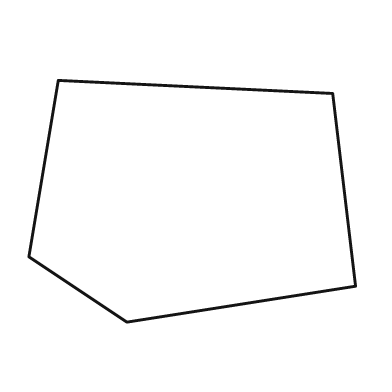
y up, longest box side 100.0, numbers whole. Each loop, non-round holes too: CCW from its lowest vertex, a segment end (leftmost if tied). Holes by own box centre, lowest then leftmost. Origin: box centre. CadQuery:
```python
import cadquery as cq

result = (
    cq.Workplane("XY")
    .moveTo(-20.0, -37.0)
    .lineTo(50.0, -26.0)
    .lineTo(43.0, 33.0)
    .lineTo(-41.0, 37.0)
    .lineTo(-50.0, -17.0)
    .close()
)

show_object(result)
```